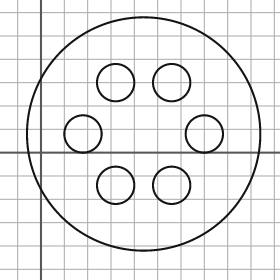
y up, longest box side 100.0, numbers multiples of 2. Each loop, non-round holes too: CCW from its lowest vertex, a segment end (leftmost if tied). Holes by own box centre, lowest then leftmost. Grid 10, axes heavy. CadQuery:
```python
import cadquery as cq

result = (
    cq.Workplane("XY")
    .moveTo(44.0, 8.0)
    .circle(50.0)
    .moveTo(32.0, -14.0)
    .circle(8.0)
    .moveTo(56.0, -14.0)
    .circle(8.0)
    .moveTo(18.0, 8.0)
    .circle(8.0)
    .moveTo(70.0, 8.0)
    .circle(8.0)
    .moveTo(32.0, 30.0)
    .circle(8.0)
    .moveTo(56.0, 30.0)
    .circle(8.0)
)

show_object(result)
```